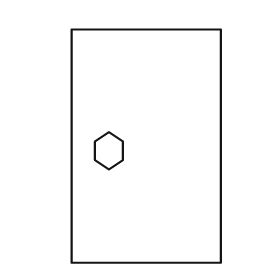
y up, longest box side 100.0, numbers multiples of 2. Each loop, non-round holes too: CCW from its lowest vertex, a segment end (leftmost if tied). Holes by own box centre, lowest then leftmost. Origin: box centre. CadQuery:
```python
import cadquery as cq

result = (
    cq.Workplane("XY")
    .moveTo(-32.0, -50.0)
    .lineTo(32.0, -50.0)
    .lineTo(32.0, 50.0)
    .lineTo(-32.0, 50.0)
    .close()
    .moveTo(-16.0, -10.0)
    .lineTo(-10.0, -6.0)
    .lineTo(-10.0, 2.0)
    .lineTo(-16.0, 6.0)
    .lineTo(-22.0, 2.0)
    .lineTo(-22.0, -6.0)
    .close()
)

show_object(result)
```